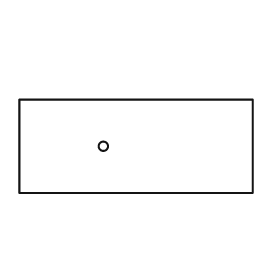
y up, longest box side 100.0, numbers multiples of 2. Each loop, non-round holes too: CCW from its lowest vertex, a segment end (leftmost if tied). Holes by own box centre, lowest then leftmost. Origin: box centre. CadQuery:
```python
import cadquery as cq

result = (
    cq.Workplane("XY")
    .moveTo(-50.0, -20.0)
    .lineTo(50.0, -20.0)
    .lineTo(50.0, 20.0)
    .lineTo(-50.0, 20.0)
    .close()
    .moveTo(-14.0, 0.0)
    .circle(2.0)
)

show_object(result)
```